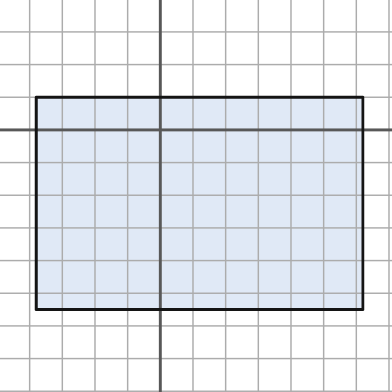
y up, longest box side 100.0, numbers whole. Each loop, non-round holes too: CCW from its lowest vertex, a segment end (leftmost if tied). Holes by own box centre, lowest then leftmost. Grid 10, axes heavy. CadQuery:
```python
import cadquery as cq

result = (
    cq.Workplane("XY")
    .moveTo(-38.0, -55.0)
    .lineTo(62.0, -55.0)
    .lineTo(62.0, 10.0)
    .lineTo(-38.0, 10.0)
    .close()
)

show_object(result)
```